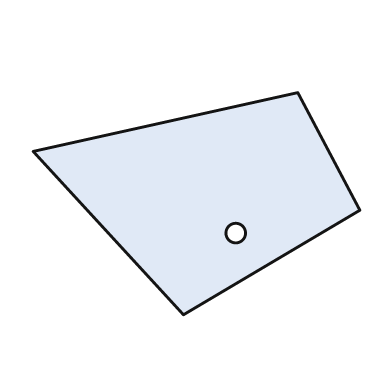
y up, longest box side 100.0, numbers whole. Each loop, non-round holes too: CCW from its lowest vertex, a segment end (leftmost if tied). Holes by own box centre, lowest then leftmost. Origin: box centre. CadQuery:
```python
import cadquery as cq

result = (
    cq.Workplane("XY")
    .moveTo(-4.0, -34.0)
    .lineTo(50.0, -2.0)
    .lineTo(31.0, 34.0)
    .lineTo(-50.0, 16.0)
    .close()
    .moveTo(12.0, -9.0)
    .circle(3.0)
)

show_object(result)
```